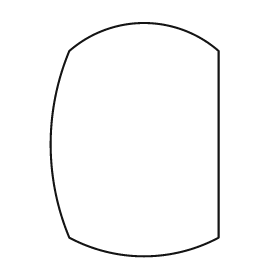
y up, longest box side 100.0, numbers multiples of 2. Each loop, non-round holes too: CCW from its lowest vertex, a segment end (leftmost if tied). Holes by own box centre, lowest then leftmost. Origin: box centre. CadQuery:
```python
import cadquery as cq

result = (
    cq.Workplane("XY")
    .moveTo(-28.0, -42.0)
    .threePointArc((4.0, -50.0), (36.0, -42.0))
    .lineTo(36.0, 38.0)
    .threePointArc((4.0, 50.0), (-28.0, 38.0))
    .threePointArc((-36.0, -2.0), (-28.0, -42.0))
    .close()
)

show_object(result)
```